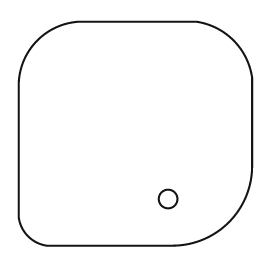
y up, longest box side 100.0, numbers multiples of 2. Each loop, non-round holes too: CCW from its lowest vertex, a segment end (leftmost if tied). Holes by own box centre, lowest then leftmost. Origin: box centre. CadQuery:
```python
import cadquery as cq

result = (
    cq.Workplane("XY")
    .moveTo(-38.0, -48.0)
    .lineTo(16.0, -48.0)
    .threePointArc((40.0, -38.0), (50.0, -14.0))
    .lineTo(50.0, 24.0)
    .threePointArc((42.0, 40.0), (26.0, 48.0))
    .lineTo(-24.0, 48.0)
    .threePointArc((-42.0, 40.0), (-50.0, 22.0))
    .lineTo(-50.0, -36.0)
    .threePointArc((-46.0, -44.0), (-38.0, -48.0))
    .close()
    .moveTo(14.0, -28.0)
    .circle(4.0)
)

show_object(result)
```